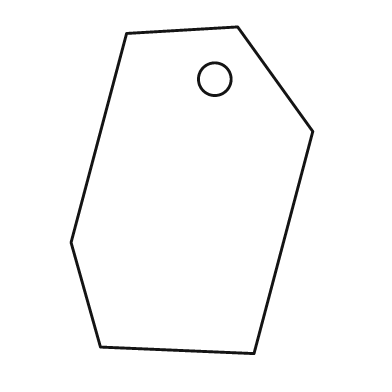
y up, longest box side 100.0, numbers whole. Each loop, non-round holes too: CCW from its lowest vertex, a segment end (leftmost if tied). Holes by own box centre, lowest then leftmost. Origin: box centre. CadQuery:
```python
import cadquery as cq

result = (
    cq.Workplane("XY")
    .moveTo(19.0, -50.0)
    .lineTo(37.0, 18.0)
    .lineTo(14.0, 50.0)
    .lineTo(-20.0, 48.0)
    .lineTo(-37.0, -16.0)
    .lineTo(-28.0, -48.0)
    .close()
    .moveTo(7.0, 34.0)
    .circle(5.0)
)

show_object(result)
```